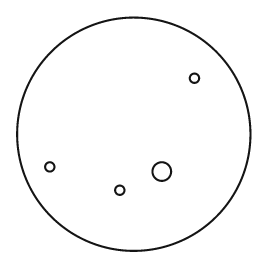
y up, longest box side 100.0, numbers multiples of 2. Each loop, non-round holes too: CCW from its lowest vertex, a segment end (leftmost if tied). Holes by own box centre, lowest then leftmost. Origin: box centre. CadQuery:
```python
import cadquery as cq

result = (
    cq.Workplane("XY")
    .moveTo(0.0, 0.0)
    .circle(50.0)
    .moveTo(-6.0, -24.0)
    .circle(2.0)
    .moveTo(12.0, -16.0)
    .circle(4.0)
    .moveTo(-36.0, -14.0)
    .circle(2.0)
    .moveTo(26.0, 24.0)
    .circle(2.0)
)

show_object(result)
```